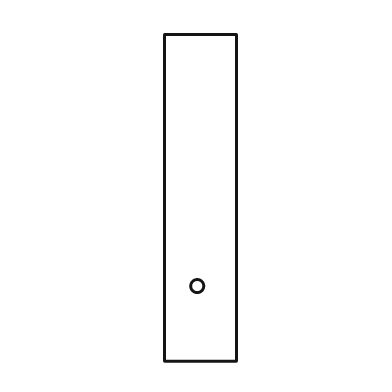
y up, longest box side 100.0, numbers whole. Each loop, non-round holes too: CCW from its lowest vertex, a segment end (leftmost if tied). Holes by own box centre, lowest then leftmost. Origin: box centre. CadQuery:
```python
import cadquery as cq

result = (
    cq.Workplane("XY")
    .moveTo(-11.0, -50.0)
    .lineTo(11.0, -50.0)
    .lineTo(11.0, 50.0)
    .lineTo(-11.0, 50.0)
    .close()
    .moveTo(-1.0, -27.0)
    .circle(2.0)
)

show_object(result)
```